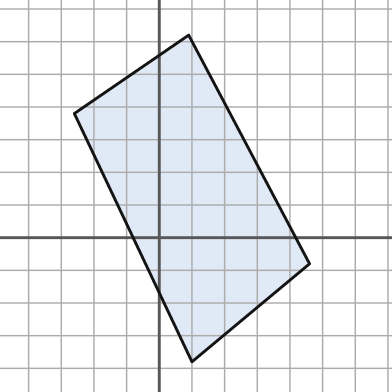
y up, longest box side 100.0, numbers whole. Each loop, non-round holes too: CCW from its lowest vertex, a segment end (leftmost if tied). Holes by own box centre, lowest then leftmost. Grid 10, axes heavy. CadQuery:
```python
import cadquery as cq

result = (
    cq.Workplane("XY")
    .moveTo(10.0, -38.0)
    .lineTo(46.0, -8.0)
    .lineTo(9.0, 62.0)
    .lineTo(-26.0, 38.0)
    .close()
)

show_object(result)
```